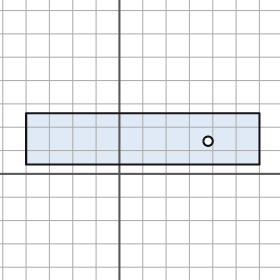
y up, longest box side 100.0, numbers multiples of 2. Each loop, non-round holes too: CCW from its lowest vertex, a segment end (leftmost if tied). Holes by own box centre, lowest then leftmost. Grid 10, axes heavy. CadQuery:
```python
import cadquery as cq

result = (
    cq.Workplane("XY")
    .moveTo(-40.0, 4.0)
    .lineTo(60.0, 4.0)
    .lineTo(60.0, 26.0)
    .lineTo(-40.0, 26.0)
    .close()
    .moveTo(38.0, 14.0)
    .circle(2.0)
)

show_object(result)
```